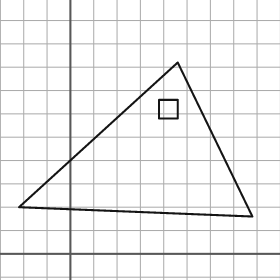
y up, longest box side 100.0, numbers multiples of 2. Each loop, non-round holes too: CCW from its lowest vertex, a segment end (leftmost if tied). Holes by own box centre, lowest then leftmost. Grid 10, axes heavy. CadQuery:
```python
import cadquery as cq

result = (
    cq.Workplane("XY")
    .moveTo(78.0, 16.0)
    .lineTo(46.0, 82.0)
    .lineTo(-22.0, 20.0)
    .close()
    .moveTo(38.0, 58.0)
    .lineTo(46.0, 58.0)
    .lineTo(46.0, 66.0)
    .lineTo(38.0, 66.0)
    .close()
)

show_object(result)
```